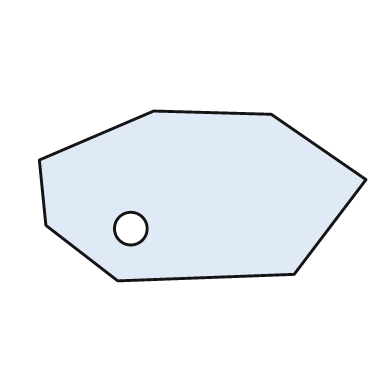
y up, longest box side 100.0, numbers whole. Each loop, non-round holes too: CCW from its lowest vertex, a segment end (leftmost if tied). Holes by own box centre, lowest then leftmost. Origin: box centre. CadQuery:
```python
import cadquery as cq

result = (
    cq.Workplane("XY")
    .moveTo(-26.0, -26.0)
    .lineTo(28.0, -24.0)
    .lineTo(50.0, 5.0)
    .lineTo(21.0, 25.0)
    .lineTo(-15.0, 26.0)
    .lineTo(-50.0, 11.0)
    .lineTo(-48.0, -9.0)
    .close()
    .moveTo(-22.0, -10.0)
    .circle(5.0)
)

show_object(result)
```